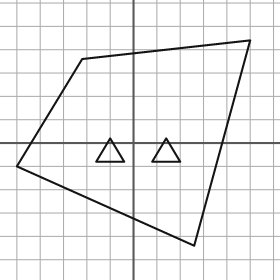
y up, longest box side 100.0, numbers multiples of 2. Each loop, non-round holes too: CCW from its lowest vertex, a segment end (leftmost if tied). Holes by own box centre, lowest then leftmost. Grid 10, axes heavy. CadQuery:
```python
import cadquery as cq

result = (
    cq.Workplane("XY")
    .moveTo(26.0, -44.0)
    .lineTo(50.0, 44.0)
    .lineTo(-22.0, 36.0)
    .lineTo(-50.0, -10.0)
    .close()
    .moveTo(-16.0, -8.0)
    .lineTo(-4.0, -8.0)
    .lineTo(-10.0, 2.0)
    .close()
    .moveTo(8.0, -8.0)
    .lineTo(20.0, -8.0)
    .lineTo(14.0, 2.0)
    .close()
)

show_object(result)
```